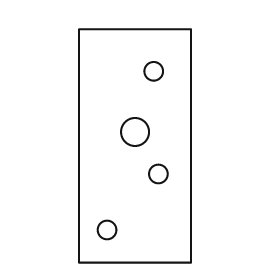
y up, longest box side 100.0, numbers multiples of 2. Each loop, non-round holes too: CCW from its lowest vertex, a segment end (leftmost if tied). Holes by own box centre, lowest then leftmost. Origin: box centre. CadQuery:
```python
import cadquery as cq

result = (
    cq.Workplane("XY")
    .moveTo(-24.0, -50.0)
    .lineTo(24.0, -50.0)
    .lineTo(24.0, 50.0)
    .lineTo(-24.0, 50.0)
    .close()
    .moveTo(-12.0, -36.0)
    .circle(4.0)
    .moveTo(10.0, -12.0)
    .circle(4.0)
    .moveTo(0.0, 6.0)
    .circle(6.0)
    .moveTo(8.0, 32.0)
    .circle(4.0)
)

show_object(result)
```